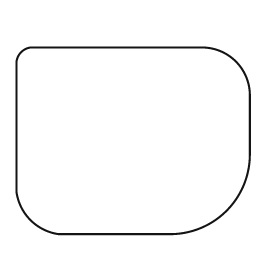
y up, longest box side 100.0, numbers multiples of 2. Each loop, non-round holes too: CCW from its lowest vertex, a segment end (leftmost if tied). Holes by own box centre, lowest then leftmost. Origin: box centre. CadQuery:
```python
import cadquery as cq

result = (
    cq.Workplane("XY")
    .moveTo(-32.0, -40.0)
    .lineTo(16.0, -40.0)
    .threePointArc((40.0, -30.0), (50.0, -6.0))
    .lineTo(50.0, 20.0)
    .threePointArc((44.0, 34.0), (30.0, 40.0))
    .lineTo(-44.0, 40.0)
    .threePointArc((-48.0, 38.0), (-50.0, 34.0))
    .lineTo(-50.0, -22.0)
    .threePointArc((-44.0, -34.0), (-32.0, -40.0))
    .close()
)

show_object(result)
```